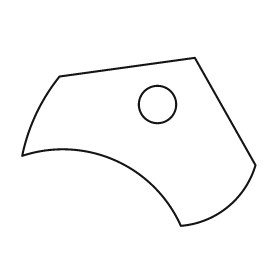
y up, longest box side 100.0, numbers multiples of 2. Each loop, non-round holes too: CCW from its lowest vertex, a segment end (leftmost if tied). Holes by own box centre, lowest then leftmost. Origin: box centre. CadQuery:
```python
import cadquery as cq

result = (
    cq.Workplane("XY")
    .moveTo(18.0, -36.0)
    .threePointArc((38.0, -28.0), (50.0, -10.0))
    .lineTo(24.0, 36.0)
    .lineTo(-34.0, 28.0)
    .threePointArc((-44.0, 12.0), (-50.0, -6.0))
    .threePointArc((-10.0, -8.0), (18.0, -36.0))
    .close()
    .moveTo(8.0, 16.0)
    .circle(8.0)
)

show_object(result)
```